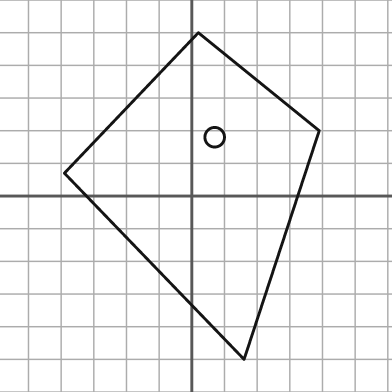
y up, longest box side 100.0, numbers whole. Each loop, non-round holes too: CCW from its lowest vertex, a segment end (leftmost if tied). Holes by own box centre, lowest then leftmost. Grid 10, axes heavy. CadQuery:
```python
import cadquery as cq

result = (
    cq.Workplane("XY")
    .moveTo(16.0, -50.0)
    .lineTo(39.0, 20.0)
    .lineTo(2.0, 50.0)
    .lineTo(-39.0, 7.0)
    .close()
    .moveTo(7.0, 18.0)
    .circle(3.0)
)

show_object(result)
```